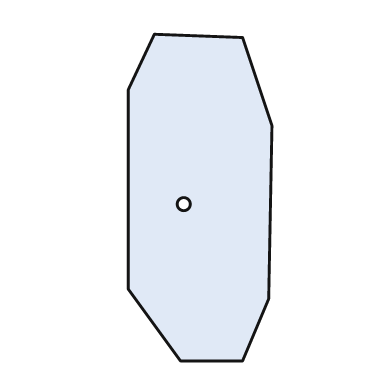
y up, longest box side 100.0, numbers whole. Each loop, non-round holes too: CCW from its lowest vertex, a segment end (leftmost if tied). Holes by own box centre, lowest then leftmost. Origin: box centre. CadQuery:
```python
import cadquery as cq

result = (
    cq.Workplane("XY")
    .moveTo(-6.0, -50.0)
    .lineTo(13.0, -50.0)
    .lineTo(21.0, -31.0)
    .lineTo(22.0, 22.0)
    .lineTo(13.0, 49.0)
    .lineTo(-14.0, 50.0)
    .lineTo(-22.0, 33.0)
    .lineTo(-22.0, -28.0)
    .close()
    .moveTo(-5.0, -2.0)
    .circle(2.0)
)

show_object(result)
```